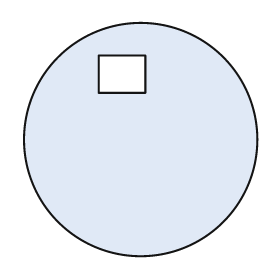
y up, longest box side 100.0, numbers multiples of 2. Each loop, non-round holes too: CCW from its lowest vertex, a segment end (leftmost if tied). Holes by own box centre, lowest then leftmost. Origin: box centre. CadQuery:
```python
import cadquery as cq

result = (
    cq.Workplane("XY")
    .moveTo(0.0, 0.0)
    .circle(50.0)
    .moveTo(-18.0, 20.0)
    .lineTo(2.0, 20.0)
    .lineTo(2.0, 36.0)
    .lineTo(-18.0, 36.0)
    .close()
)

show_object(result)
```